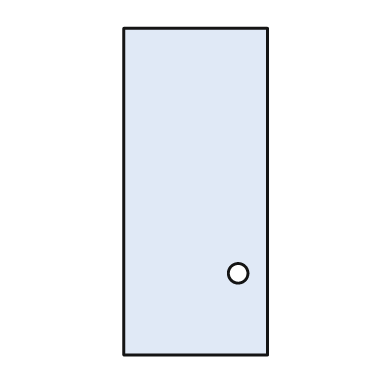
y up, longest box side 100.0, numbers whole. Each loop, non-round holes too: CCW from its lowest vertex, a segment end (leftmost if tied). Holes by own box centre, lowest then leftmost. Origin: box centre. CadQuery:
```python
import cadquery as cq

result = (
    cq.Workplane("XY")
    .moveTo(-22.0, -50.0)
    .lineTo(22.0, -50.0)
    .lineTo(22.0, 50.0)
    .lineTo(-22.0, 50.0)
    .close()
    .moveTo(13.0, -25.0)
    .circle(3.0)
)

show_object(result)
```